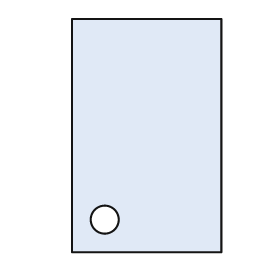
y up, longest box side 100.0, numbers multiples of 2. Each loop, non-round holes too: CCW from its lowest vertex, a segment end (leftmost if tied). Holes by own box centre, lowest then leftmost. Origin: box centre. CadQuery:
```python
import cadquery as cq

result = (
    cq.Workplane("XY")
    .moveTo(-32.0, -50.0)
    .lineTo(32.0, -50.0)
    .lineTo(32.0, 50.0)
    .lineTo(-32.0, 50.0)
    .close()
    .moveTo(-18.0, -36.0)
    .circle(6.0)
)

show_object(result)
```